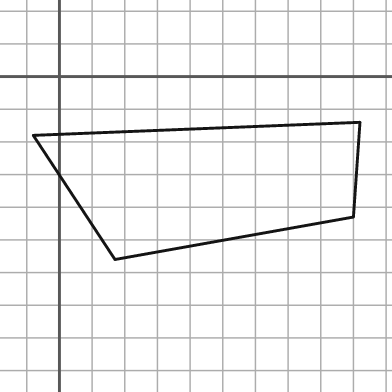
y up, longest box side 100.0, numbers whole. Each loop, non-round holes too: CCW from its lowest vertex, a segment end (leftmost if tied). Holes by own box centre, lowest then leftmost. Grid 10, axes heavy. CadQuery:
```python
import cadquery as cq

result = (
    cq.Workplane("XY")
    .moveTo(17.0, -56.0)
    .lineTo(90.0, -43.0)
    .lineTo(92.0, -14.0)
    .lineTo(-8.0, -18.0)
    .close()
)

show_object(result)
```